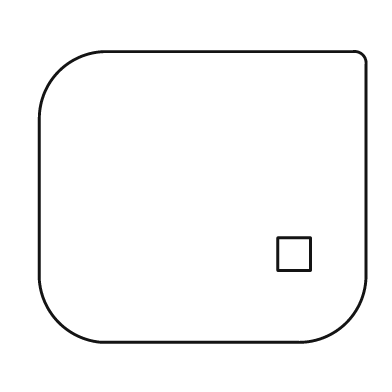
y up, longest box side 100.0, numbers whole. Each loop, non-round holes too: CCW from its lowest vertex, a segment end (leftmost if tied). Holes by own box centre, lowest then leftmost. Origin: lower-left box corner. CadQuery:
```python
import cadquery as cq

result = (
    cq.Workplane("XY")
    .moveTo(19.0, 0.0)
    .lineTo(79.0, 0.0)
    .threePointArc((94.0, 6.0), (100.0, 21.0))
    .lineTo(100.0, 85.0)
    .threePointArc((99.0, 88.0), (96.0, 89.0))
    .lineTo(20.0, 89.0)
    .threePointArc((6.0, 83.0), (0.0, 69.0))
    .lineTo(0.0, 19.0)
    .threePointArc((6.0, 6.0), (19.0, 0.0))
    .close()
    .moveTo(73.0, 22.0)
    .lineTo(83.0, 22.0)
    .lineTo(83.0, 32.0)
    .lineTo(73.0, 32.0)
    .close()
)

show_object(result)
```